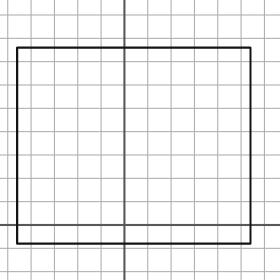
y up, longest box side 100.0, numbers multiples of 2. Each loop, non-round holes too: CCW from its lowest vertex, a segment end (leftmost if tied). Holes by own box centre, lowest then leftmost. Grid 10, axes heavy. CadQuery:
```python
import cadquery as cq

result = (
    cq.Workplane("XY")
    .moveTo(-46.0, -8.0)
    .lineTo(54.0, -8.0)
    .lineTo(54.0, 76.0)
    .lineTo(-46.0, 76.0)
    .close()
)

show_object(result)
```